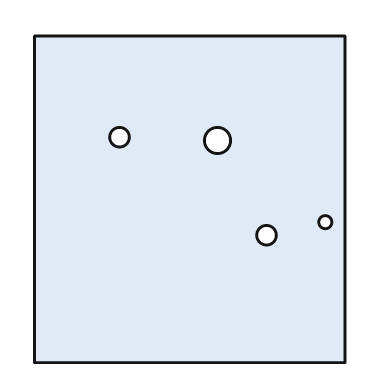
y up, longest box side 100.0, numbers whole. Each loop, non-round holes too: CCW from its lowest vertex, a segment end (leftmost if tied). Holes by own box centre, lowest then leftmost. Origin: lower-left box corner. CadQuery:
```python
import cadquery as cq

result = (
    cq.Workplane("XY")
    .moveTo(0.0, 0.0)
    .lineTo(95.0, 0.0)
    .lineTo(95.0, 100.0)
    .lineTo(0.0, 100.0)
    .close()
    .moveTo(71.0, 39.0)
    .circle(3.0)
    .moveTo(89.0, 43.0)
    .circle(2.0)
    .moveTo(56.0, 68.0)
    .circle(4.0)
    .moveTo(26.0, 69.0)
    .circle(3.0)
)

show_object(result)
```